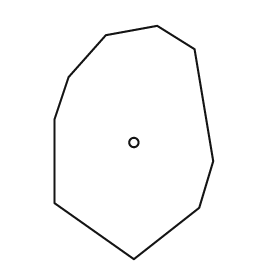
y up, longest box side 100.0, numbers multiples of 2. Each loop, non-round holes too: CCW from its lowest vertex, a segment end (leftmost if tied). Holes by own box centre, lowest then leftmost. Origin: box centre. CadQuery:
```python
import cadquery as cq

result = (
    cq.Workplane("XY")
    .moveTo(0.0, -50.0)
    .lineTo(28.0, -28.0)
    .lineTo(34.0, -8.0)
    .lineTo(26.0, 40.0)
    .lineTo(10.0, 50.0)
    .lineTo(-12.0, 46.0)
    .lineTo(-28.0, 28.0)
    .lineTo(-34.0, 10.0)
    .lineTo(-34.0, -26.0)
    .close()
    .moveTo(0.0, 0.0)
    .circle(2.0)
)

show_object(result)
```